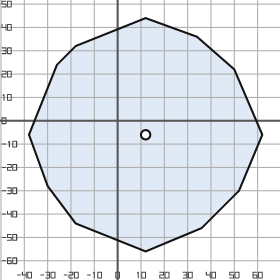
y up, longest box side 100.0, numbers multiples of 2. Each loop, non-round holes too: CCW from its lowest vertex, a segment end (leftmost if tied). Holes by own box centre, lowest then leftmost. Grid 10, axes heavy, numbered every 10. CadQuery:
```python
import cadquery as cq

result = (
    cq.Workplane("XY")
    .moveTo(12.0, -56.0)
    .lineTo(36.0, -46.0)
    .lineTo(52.0, -30.0)
    .lineTo(62.0, -6.0)
    .lineTo(50.0, 22.0)
    .lineTo(34.0, 36.0)
    .lineTo(12.0, 44.0)
    .lineTo(-18.0, 32.0)
    .lineTo(-26.0, 24.0)
    .lineTo(-38.0, -6.0)
    .lineTo(-30.0, -28.0)
    .lineTo(-18.0, -44.0)
    .close()
    .moveTo(12.0, -6.0)
    .circle(2.0)
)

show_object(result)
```